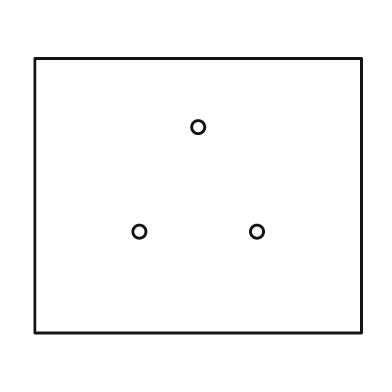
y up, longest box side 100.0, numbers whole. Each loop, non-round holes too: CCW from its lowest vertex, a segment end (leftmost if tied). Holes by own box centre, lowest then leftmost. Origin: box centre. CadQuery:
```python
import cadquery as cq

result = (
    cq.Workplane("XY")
    .moveTo(-50.0, -42.0)
    .lineTo(50.0, -42.0)
    .lineTo(50.0, 42.0)
    .lineTo(-50.0, 42.0)
    .close()
    .moveTo(-18.0, -11.0)
    .circle(2.0)
    .moveTo(18.0, -11.0)
    .circle(2.0)
    .moveTo(0.0, 21.0)
    .circle(2.0)
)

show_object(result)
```